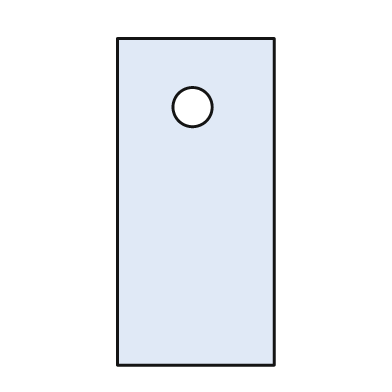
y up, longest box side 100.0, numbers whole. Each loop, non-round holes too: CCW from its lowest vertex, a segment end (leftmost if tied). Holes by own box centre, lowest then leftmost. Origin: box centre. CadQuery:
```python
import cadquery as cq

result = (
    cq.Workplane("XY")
    .moveTo(-24.0, -50.0)
    .lineTo(24.0, -50.0)
    .lineTo(24.0, 50.0)
    .lineTo(-24.0, 50.0)
    .close()
    .moveTo(-1.0, 29.0)
    .circle(6.0)
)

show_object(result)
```